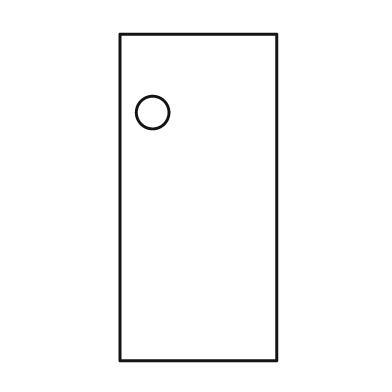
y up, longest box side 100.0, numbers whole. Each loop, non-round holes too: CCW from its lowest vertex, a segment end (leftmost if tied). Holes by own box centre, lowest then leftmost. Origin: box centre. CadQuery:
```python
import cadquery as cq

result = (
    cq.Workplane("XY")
    .moveTo(-24.0, -50.0)
    .lineTo(24.0, -50.0)
    .lineTo(24.0, 50.0)
    .lineTo(-24.0, 50.0)
    .close()
    .moveTo(-14.0, 26.0)
    .circle(5.0)
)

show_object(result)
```